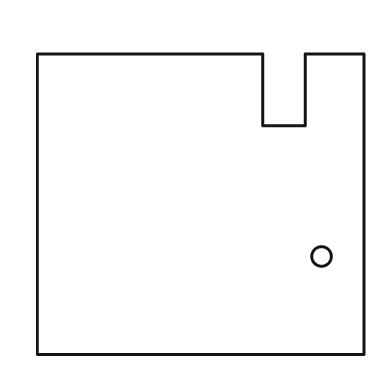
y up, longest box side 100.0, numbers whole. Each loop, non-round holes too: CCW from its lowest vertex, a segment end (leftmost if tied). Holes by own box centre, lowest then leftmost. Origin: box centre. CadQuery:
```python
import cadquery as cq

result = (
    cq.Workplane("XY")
    .moveTo(-50.0, -46.0)
    .lineTo(50.0, -46.0)
    .lineTo(50.0, 46.0)
    .lineTo(32.0, 46.0)
    .lineTo(32.0, 24.0)
    .lineTo(19.0, 24.0)
    .lineTo(19.0, 46.0)
    .lineTo(-50.0, 46.0)
    .close()
    .moveTo(37.0, -16.0)
    .circle(3.0)
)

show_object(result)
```